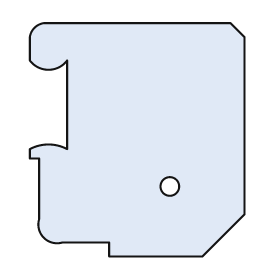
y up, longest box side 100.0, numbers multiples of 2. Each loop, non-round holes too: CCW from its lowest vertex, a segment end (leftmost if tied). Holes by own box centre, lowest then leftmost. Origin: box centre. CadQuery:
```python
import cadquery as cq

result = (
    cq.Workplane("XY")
    .moveTo(-12.0, -50.0)
    .lineTo(28.0, -50.0)
    .lineTo(46.0, -32.0)
    .lineTo(46.0, 44.0)
    .lineTo(40.0, 50.0)
    .lineTo(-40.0, 50.0)
    .threePointArc((-44.0, 48.0), (-46.0, 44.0))
    .lineTo(-46.0, 34.0)
    .threePointArc((-38.0, 30.0), (-30.0, 34.0))
    .lineTo(-30.0, -4.0)
    .threePointArc((-38.0, -2.0), (-46.0, -4.0))
    .lineTo(-46.0, -8.0)
    .lineTo(-42.0, -8.0)
    .lineTo(-42.0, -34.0)
    .threePointArc((-40.0, -42.0), (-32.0, -44.0))
    .lineTo(-12.0, -44.0)
    .close()
    .moveTo(14.0, -20.0)
    .circle(4.0)
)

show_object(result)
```